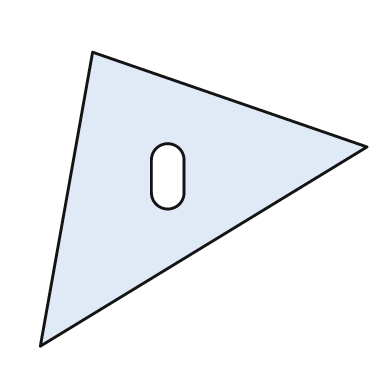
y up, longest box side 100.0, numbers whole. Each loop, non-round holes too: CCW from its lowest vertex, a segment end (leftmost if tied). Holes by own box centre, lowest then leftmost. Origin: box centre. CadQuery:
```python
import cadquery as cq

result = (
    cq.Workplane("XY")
    .moveTo(-50.0, -45.0)
    .lineTo(50.0, 16.0)
    .lineTo(-34.0, 45.0)
    .close()
    .moveTo(-16.0, 2.0)
    .threePointArc((-11.0, -3.0), (-6.0, 2.0))
    .lineTo(-6.0, 12.0)
    .threePointArc((-11.0, 17.0), (-16.0, 12.0))
    .close()
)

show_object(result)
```